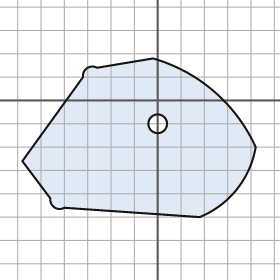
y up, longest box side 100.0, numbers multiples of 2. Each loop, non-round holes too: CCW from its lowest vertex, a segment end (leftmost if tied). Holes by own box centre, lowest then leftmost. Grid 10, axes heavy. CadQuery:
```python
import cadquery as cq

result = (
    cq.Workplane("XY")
    .moveTo(18.0, -50.0)
    .threePointArc((34.0, -38.0), (42.0, -20.0))
    .threePointArc((24.0, 4.0), (-2.0, 18.0))
    .lineTo(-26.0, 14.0)
    .threePointArc((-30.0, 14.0), (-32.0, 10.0))
    .lineTo(-58.0, -26.0)
    .lineTo(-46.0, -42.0)
    .threePointArc((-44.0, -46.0), (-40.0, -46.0))
    .close()
    .moveTo(0.0, -10.0)
    .circle(4.0)
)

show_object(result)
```